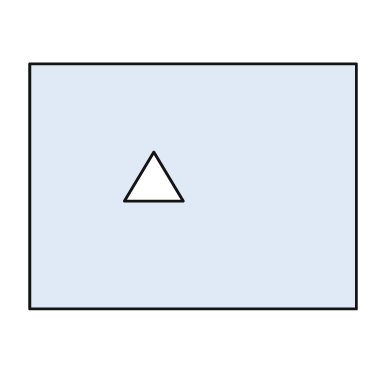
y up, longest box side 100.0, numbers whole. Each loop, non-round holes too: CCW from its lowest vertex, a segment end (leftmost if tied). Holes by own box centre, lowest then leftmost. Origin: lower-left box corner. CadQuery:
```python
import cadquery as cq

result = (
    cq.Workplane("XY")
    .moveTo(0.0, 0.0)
    .lineTo(100.0, 0.0)
    .lineTo(100.0, 75.0)
    .lineTo(0.0, 75.0)
    .close()
    .moveTo(29.0, 33.0)
    .lineTo(47.0, 33.0)
    .lineTo(38.0, 48.0)
    .close()
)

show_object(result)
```